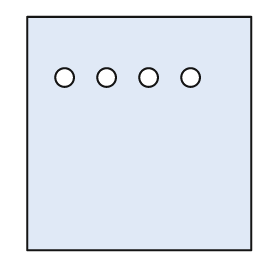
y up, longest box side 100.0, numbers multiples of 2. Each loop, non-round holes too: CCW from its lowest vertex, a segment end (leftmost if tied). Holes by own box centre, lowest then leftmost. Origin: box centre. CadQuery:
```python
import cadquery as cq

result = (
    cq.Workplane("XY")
    .moveTo(-48.0, -50.0)
    .lineTo(48.0, -50.0)
    .lineTo(48.0, 50.0)
    .lineTo(-48.0, 50.0)
    .close()
    .moveTo(-32.0, 24.0)
    .circle(4.0)
    .moveTo(-14.0, 24.0)
    .circle(4.0)
    .moveTo(4.0, 24.0)
    .circle(4.0)
    .moveTo(22.0, 24.0)
    .circle(4.0)
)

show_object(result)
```